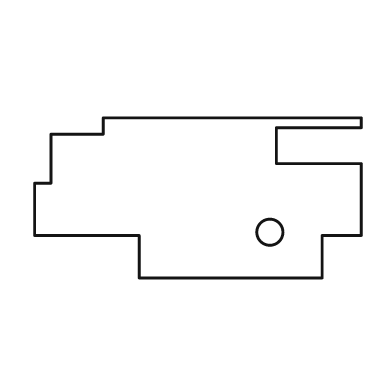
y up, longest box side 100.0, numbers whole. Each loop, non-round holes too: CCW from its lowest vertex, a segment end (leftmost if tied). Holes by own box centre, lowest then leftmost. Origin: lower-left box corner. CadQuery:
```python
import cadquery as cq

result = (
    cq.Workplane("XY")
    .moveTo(32.0, 0.0)
    .lineTo(88.0, 0.0)
    .lineTo(88.0, 13.0)
    .lineTo(100.0, 13.0)
    .lineTo(100.0, 35.0)
    .lineTo(74.0, 35.0)
    .lineTo(74.0, 46.0)
    .lineTo(100.0, 46.0)
    .lineTo(100.0, 49.0)
    .lineTo(21.0, 49.0)
    .lineTo(21.0, 44.0)
    .lineTo(5.0, 44.0)
    .lineTo(5.0, 29.0)
    .lineTo(0.0, 29.0)
    .lineTo(0.0, 13.0)
    .lineTo(32.0, 13.0)
    .close()
    .moveTo(72.0, 14.0)
    .circle(4.0)
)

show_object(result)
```